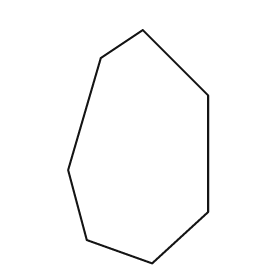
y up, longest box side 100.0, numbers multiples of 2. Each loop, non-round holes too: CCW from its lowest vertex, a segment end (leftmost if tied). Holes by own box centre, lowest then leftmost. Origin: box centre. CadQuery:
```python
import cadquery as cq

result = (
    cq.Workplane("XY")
    .moveTo(6.0, -50.0)
    .lineTo(30.0, -28.0)
    .lineTo(30.0, 22.0)
    .lineTo(2.0, 50.0)
    .lineTo(-16.0, 38.0)
    .lineTo(-30.0, -10.0)
    .lineTo(-22.0, -40.0)
    .close()
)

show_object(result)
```